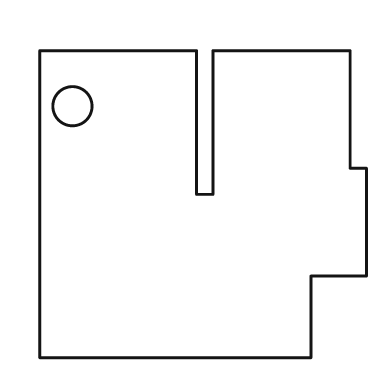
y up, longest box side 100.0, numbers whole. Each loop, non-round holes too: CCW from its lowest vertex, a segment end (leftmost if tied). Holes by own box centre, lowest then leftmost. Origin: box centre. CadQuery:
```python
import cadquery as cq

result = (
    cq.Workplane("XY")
    .moveTo(-50.0, -47.0)
    .lineTo(33.0, -47.0)
    .lineTo(33.0, -22.0)
    .lineTo(50.0, -22.0)
    .lineTo(50.0, 11.0)
    .lineTo(45.0, 11.0)
    .lineTo(45.0, 47.0)
    .lineTo(3.0, 47.0)
    .lineTo(3.0, 3.0)
    .lineTo(-2.0, 3.0)
    .lineTo(-2.0, 47.0)
    .lineTo(-50.0, 47.0)
    .close()
    .moveTo(-40.0, 30.0)
    .circle(6.0)
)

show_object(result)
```